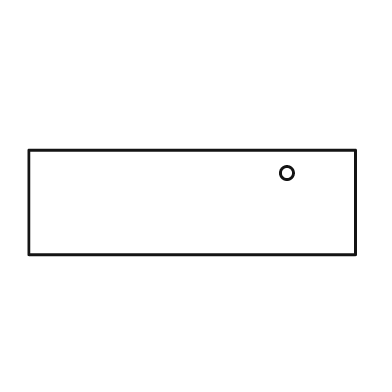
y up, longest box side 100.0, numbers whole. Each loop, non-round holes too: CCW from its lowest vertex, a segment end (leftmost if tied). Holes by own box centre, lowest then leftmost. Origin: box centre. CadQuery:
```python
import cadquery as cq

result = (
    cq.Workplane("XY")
    .moveTo(-50.0, -16.0)
    .lineTo(50.0, -16.0)
    .lineTo(50.0, 16.0)
    .lineTo(-50.0, 16.0)
    .close()
    .moveTo(29.0, 9.0)
    .circle(2.0)
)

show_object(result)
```